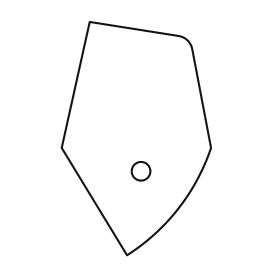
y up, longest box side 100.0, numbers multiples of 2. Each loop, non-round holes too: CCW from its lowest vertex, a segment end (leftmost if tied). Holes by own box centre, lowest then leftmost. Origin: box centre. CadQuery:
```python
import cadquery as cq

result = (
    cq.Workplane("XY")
    .moveTo(-4.0, -50.0)
    .threePointArc((18.0, -30.0), (32.0, -4.0))
    .lineTo(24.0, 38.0)
    .threePointArc((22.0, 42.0), (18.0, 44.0))
    .lineTo(-20.0, 50.0)
    .lineTo(-32.0, -4.0)
    .close()
    .moveTo(2.0, -14.0)
    .circle(4.0)
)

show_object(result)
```